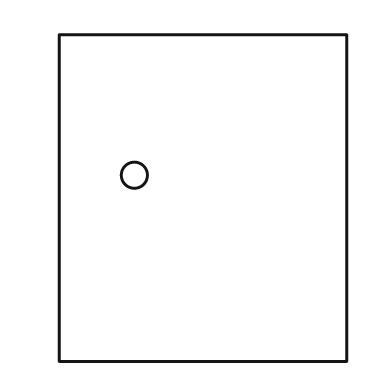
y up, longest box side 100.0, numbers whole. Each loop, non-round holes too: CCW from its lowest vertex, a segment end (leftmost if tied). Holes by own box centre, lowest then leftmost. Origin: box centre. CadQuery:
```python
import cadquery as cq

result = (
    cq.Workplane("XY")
    .moveTo(-44.0, -50.0)
    .lineTo(44.0, -50.0)
    .lineTo(44.0, 50.0)
    .lineTo(-44.0, 50.0)
    .close()
    .moveTo(-21.0, 7.0)
    .circle(4.0)
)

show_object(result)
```